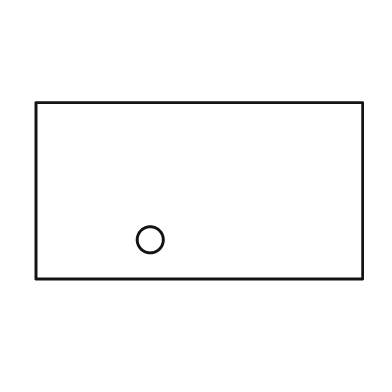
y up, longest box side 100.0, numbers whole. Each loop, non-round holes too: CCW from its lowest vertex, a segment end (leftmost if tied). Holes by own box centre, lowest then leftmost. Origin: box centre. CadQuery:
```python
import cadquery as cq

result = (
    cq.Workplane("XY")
    .moveTo(-50.0, -27.0)
    .lineTo(50.0, -27.0)
    .lineTo(50.0, 27.0)
    .lineTo(-50.0, 27.0)
    .close()
    .moveTo(-15.0, -15.0)
    .circle(4.0)
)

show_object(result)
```